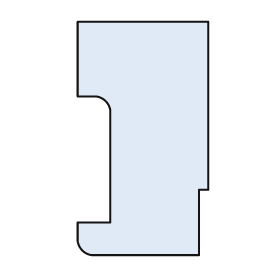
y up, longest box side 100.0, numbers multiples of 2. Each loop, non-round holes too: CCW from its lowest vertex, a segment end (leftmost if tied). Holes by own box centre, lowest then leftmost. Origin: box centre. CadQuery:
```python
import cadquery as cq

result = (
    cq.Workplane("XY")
    .moveTo(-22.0, -50.0)
    .lineTo(24.0, -50.0)
    .lineTo(24.0, -22.0)
    .lineTo(28.0, -22.0)
    .lineTo(28.0, 50.0)
    .lineTo(-28.0, 50.0)
    .lineTo(-28.0, 18.0)
    .lineTo(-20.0, 18.0)
    .threePointArc((-16.0, 16.0), (-14.0, 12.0))
    .lineTo(-14.0, -36.0)
    .lineTo(-28.0, -36.0)
    .lineTo(-28.0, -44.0)
    .threePointArc((-26.0, -48.0), (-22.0, -50.0))
    .close()
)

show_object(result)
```